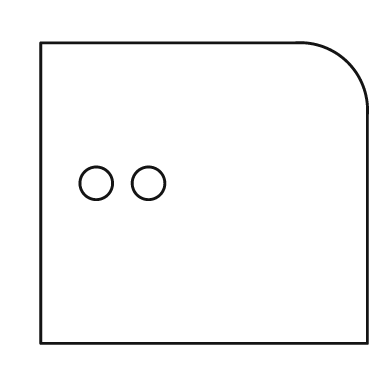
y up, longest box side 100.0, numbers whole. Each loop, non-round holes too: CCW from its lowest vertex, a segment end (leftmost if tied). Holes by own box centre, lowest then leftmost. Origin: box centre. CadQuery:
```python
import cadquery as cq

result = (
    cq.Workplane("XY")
    .moveTo(-50.0, -46.0)
    .lineTo(50.0, -46.0)
    .lineTo(50.0, 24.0)
    .threePointArc((44.0, 40.0), (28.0, 46.0))
    .lineTo(-50.0, 46.0)
    .close()
    .moveTo(-33.0, 3.0)
    .circle(5.0)
    .moveTo(-17.0, 3.0)
    .circle(5.0)
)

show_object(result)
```